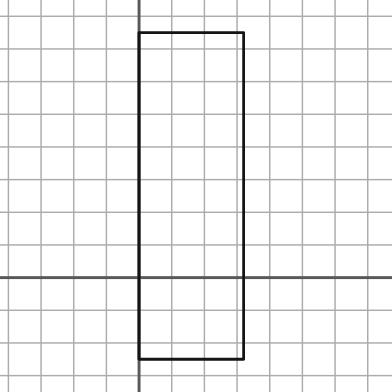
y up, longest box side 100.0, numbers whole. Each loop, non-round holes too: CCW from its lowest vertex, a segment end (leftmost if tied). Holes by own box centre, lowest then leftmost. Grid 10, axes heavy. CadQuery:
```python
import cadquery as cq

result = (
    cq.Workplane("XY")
    .moveTo(0.0, -25.0)
    .lineTo(32.0, -25.0)
    .lineTo(32.0, 75.0)
    .lineTo(0.0, 75.0)
    .close()
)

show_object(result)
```